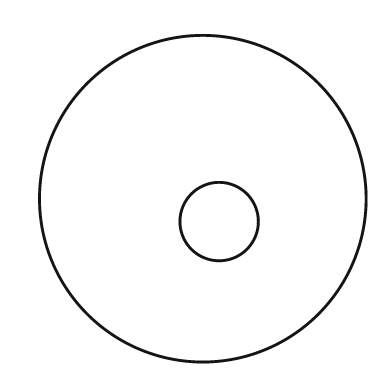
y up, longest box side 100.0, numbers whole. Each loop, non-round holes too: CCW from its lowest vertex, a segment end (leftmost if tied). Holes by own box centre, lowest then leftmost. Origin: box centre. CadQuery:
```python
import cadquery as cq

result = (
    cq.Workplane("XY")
    .moveTo(0.0, 0.0)
    .circle(50.0)
    .moveTo(5.0, -7.0)
    .circle(12.0)
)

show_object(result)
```